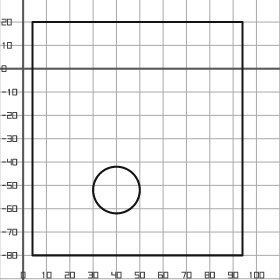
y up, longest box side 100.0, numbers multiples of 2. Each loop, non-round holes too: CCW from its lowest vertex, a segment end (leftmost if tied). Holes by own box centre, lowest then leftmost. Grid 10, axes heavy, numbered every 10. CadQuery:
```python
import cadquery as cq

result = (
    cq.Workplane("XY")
    .moveTo(4.0, -80.0)
    .lineTo(94.0, -80.0)
    .lineTo(94.0, 20.0)
    .lineTo(4.0, 20.0)
    .close()
    .moveTo(40.0, -52.0)
    .circle(10.0)
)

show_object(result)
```